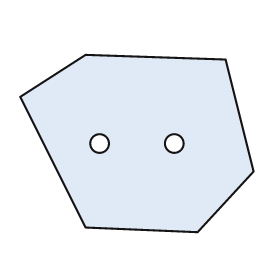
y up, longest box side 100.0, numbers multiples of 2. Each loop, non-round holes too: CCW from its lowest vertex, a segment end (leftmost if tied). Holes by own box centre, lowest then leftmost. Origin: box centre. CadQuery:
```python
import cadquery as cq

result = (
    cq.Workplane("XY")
    .moveTo(26.0, -38.0)
    .lineTo(50.0, -12.0)
    .lineTo(38.0, 36.0)
    .lineTo(-22.0, 38.0)
    .lineTo(-50.0, 20.0)
    .lineTo(-22.0, -36.0)
    .close()
    .moveTo(-16.0, 0.0)
    .circle(4.0)
    .moveTo(16.0, 0.0)
    .circle(4.0)
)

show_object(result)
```